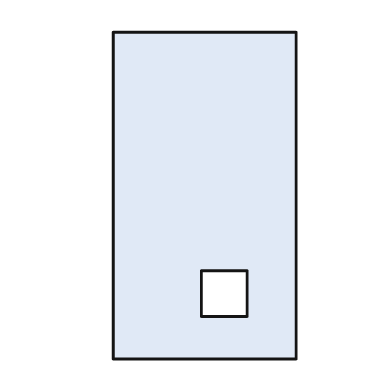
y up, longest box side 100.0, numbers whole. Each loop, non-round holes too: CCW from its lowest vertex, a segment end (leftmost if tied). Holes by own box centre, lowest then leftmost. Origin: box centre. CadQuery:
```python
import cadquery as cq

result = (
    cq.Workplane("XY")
    .moveTo(-28.0, -50.0)
    .lineTo(28.0, -50.0)
    .lineTo(28.0, 50.0)
    .lineTo(-28.0, 50.0)
    .close()
    .moveTo(-1.0, -37.0)
    .lineTo(13.0, -37.0)
    .lineTo(13.0, -23.0)
    .lineTo(-1.0, -23.0)
    .close()
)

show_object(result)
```